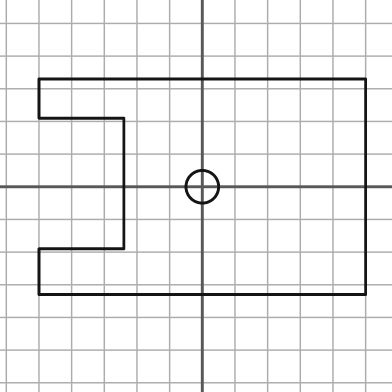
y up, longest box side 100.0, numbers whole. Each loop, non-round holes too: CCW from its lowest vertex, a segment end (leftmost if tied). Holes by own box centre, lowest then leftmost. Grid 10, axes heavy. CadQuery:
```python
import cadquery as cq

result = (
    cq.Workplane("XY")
    .moveTo(-50.0, -33.0)
    .lineTo(50.0, -33.0)
    .lineTo(50.0, 33.0)
    .lineTo(-50.0, 33.0)
    .lineTo(-50.0, 21.0)
    .lineTo(-24.0, 21.0)
    .lineTo(-24.0, -19.0)
    .lineTo(-50.0, -19.0)
    .close()
    .moveTo(0.0, 0.0)
    .circle(5.0)
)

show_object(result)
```